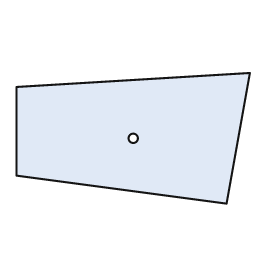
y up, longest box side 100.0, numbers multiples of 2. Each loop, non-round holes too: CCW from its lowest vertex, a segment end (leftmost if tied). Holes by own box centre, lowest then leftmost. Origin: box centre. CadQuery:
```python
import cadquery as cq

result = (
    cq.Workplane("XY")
    .moveTo(40.0, -28.0)
    .lineTo(50.0, 28.0)
    .lineTo(-50.0, 22.0)
    .lineTo(-50.0, -16.0)
    .close()
    .moveTo(0.0, 0.0)
    .circle(2.0)
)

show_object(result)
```